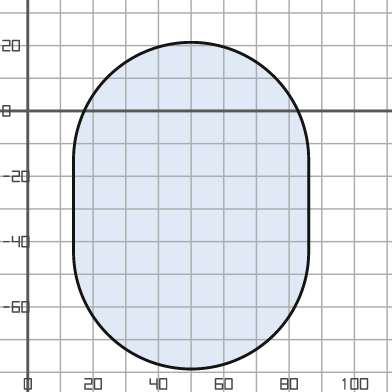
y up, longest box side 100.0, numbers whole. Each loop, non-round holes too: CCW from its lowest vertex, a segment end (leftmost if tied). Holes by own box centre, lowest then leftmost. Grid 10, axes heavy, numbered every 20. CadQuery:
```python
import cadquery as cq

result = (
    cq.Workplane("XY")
    .moveTo(14.0, -43.0)
    .threePointArc((50.0, -79.0), (86.0, -43.0))
    .lineTo(86.0, -15.0)
    .threePointArc((50.0, 21.0), (14.0, -15.0))
    .close()
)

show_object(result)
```